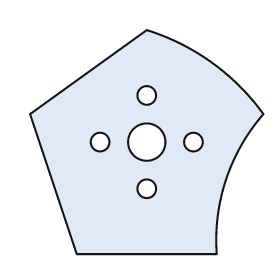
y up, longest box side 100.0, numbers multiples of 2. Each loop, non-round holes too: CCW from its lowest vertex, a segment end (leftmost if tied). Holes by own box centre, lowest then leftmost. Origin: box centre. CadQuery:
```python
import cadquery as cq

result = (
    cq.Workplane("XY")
    .moveTo(-30.0, -48.0)
    .lineTo(30.0, -48.0)
    .threePointArc((34.0, -16.0), (50.0, 12.0))
    .threePointArc((28.0, 34.0), (0.0, 48.0))
    .lineTo(-50.0, 12.0)
    .close()
    .moveTo(0.0, -20.0)
    .circle(4.0)
    .moveTo(-20.0, 0.0)
    .circle(4.0)
    .moveTo(0.0, 0.0)
    .circle(8.0)
    .moveTo(20.0, 0.0)
    .circle(4.0)
    .moveTo(0.0, 20.0)
    .circle(4.0)
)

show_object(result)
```